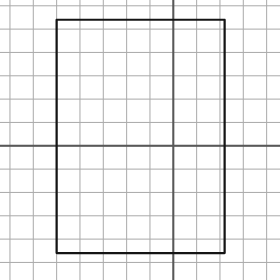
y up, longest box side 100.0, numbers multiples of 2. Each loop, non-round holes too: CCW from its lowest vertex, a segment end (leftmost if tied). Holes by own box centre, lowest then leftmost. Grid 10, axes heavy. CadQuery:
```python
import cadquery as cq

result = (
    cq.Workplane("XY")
    .moveTo(-50.0, -46.0)
    .lineTo(22.0, -46.0)
    .lineTo(22.0, 54.0)
    .lineTo(-50.0, 54.0)
    .close()
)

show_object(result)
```